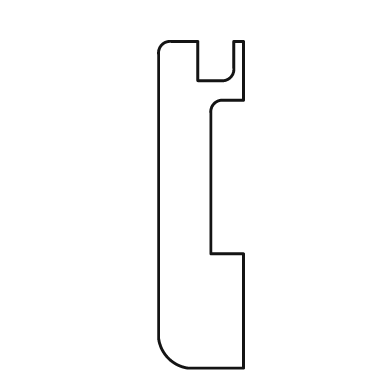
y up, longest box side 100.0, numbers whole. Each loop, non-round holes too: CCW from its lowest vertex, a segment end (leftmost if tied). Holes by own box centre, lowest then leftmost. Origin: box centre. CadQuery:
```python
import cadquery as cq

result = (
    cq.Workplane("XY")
    .moveTo(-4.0, -50.0)
    .lineTo(13.0, -50.0)
    .lineTo(13.0, -15.0)
    .lineTo(3.0, -15.0)
    .lineTo(3.0, 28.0)
    .threePointArc((4.0, 31.0), (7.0, 32.0))
    .lineTo(13.0, 32.0)
    .lineTo(13.0, 50.0)
    .lineTo(10.0, 50.0)
    .lineTo(10.0, 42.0)
    .threePointArc((9.0, 39.0), (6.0, 38.0))
    .lineTo(-1.0, 38.0)
    .lineTo(-1.0, 50.0)
    .lineTo(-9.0, 50.0)
    .threePointArc((-12.0, 49.0), (-13.0, 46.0))
    .lineTo(-13.0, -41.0)
    .threePointArc((-10.0, -47.0), (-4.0, -50.0))
    .close()
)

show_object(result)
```